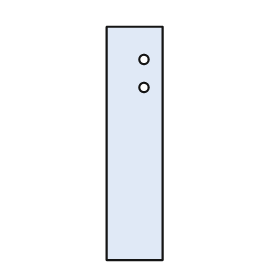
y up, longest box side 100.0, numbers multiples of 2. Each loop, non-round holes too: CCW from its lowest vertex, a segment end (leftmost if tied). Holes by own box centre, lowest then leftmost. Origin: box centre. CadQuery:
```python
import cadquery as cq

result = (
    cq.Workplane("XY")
    .moveTo(-12.0, -50.0)
    .lineTo(12.0, -50.0)
    .lineTo(12.0, 50.0)
    .lineTo(-12.0, 50.0)
    .close()
    .moveTo(4.0, 24.0)
    .circle(2.0)
    .moveTo(4.0, 36.0)
    .circle(2.0)
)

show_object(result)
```